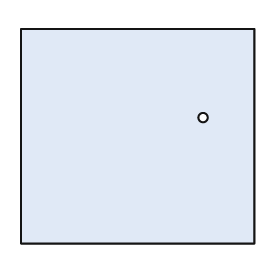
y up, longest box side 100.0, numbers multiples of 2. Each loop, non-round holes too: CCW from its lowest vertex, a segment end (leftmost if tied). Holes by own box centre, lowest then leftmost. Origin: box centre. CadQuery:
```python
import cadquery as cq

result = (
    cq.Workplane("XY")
    .moveTo(-50.0, -46.0)
    .lineTo(50.0, -46.0)
    .lineTo(50.0, 46.0)
    .lineTo(-50.0, 46.0)
    .close()
    .moveTo(28.0, 8.0)
    .circle(2.0)
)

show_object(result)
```